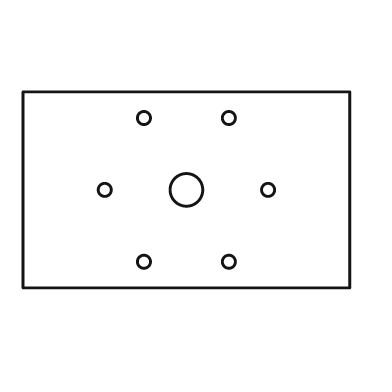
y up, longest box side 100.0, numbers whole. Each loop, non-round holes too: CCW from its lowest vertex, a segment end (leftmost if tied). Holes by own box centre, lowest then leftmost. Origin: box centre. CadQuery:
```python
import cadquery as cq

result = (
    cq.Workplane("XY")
    .moveTo(-50.0, -30.0)
    .lineTo(50.0, -30.0)
    .lineTo(50.0, 30.0)
    .lineTo(-50.0, 30.0)
    .close()
    .moveTo(-13.0, -22.0)
    .circle(2.0)
    .moveTo(13.0, -22.0)
    .circle(2.0)
    .moveTo(-25.0, 0.0)
    .circle(2.0)
    .moveTo(0.0, 0.0)
    .circle(5.0)
    .moveTo(25.0, 0.0)
    .circle(2.0)
    .moveTo(-13.0, 22.0)
    .circle(2.0)
    .moveTo(13.0, 22.0)
    .circle(2.0)
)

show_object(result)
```